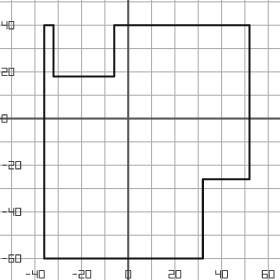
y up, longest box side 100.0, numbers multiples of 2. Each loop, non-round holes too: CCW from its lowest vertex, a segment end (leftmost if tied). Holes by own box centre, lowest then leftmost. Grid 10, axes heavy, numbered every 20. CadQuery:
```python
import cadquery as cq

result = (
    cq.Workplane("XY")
    .moveTo(-36.0, -60.0)
    .lineTo(32.0, -60.0)
    .lineTo(32.0, -26.0)
    .lineTo(52.0, -26.0)
    .lineTo(52.0, 40.0)
    .lineTo(-6.0, 40.0)
    .lineTo(-6.0, 18.0)
    .lineTo(-32.0, 18.0)
    .lineTo(-32.0, 40.0)
    .lineTo(-36.0, 40.0)
    .close()
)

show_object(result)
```